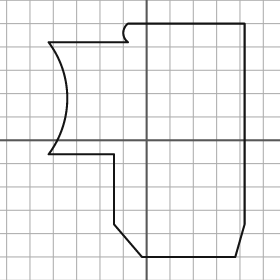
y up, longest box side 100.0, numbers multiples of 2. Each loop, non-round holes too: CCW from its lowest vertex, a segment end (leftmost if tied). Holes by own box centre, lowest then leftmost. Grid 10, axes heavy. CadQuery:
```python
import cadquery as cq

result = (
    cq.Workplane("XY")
    .moveTo(-2.0, -50.0)
    .lineTo(38.0, -50.0)
    .lineTo(42.0, -36.0)
    .lineTo(42.0, 50.0)
    .lineTo(-8.0, 50.0)
    .threePointArc((-10.0, 46.0), (-8.0, 42.0))
    .lineTo(-42.0, 42.0)
    .threePointArc((-34.0, 18.0), (-42.0, -6.0))
    .lineTo(-14.0, -6.0)
    .lineTo(-14.0, -36.0)
    .close()
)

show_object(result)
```